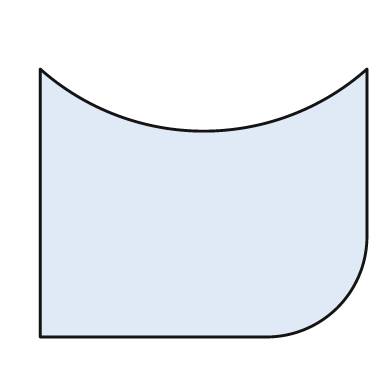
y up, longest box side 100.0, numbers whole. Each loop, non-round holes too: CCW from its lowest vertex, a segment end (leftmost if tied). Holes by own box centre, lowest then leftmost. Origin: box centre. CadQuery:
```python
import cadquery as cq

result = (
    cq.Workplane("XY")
    .moveTo(-50.0, -41.0)
    .lineTo(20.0, -41.0)
    .threePointArc((41.0, -32.0), (50.0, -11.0))
    .lineTo(50.0, 41.0)
    .threePointArc((0.0, 22.0), (-50.0, 41.0))
    .close()
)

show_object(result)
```